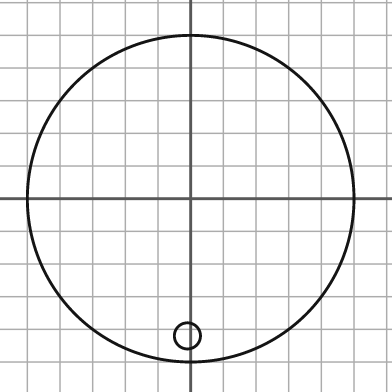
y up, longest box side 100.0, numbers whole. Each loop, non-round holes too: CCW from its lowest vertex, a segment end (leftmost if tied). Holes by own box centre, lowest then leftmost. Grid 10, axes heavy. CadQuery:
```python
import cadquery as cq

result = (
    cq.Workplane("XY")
    .moveTo(0.0, 0.0)
    .circle(50.0)
    .moveTo(-1.0, -42.0)
    .circle(4.0)
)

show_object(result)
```